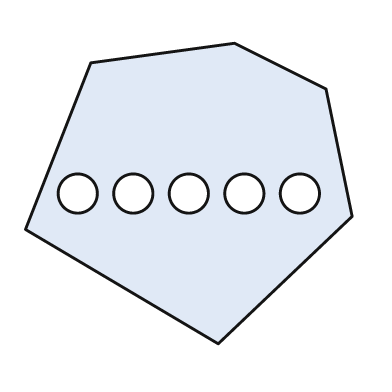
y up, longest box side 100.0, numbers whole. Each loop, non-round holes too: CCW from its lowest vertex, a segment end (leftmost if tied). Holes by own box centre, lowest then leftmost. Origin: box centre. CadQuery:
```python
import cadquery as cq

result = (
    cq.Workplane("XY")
    .moveTo(9.0, -46.0)
    .lineTo(50.0, -7.0)
    .lineTo(42.0, 32.0)
    .lineTo(14.0, 46.0)
    .lineTo(-30.0, 40.0)
    .lineTo(-50.0, -11.0)
    .close()
    .moveTo(-34.0, 0.0)
    .circle(6.0)
    .moveTo(-17.0, 0.0)
    .circle(6.0)
    .moveTo(0.0, 0.0)
    .circle(6.0)
    .moveTo(17.0, 0.0)
    .circle(6.0)
    .moveTo(34.0, 0.0)
    .circle(6.0)
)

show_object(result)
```